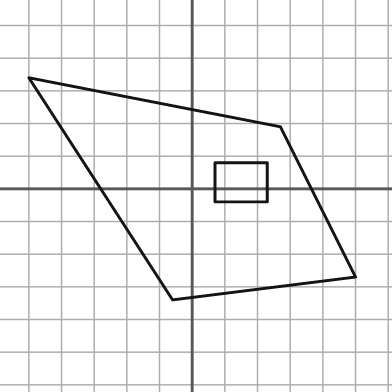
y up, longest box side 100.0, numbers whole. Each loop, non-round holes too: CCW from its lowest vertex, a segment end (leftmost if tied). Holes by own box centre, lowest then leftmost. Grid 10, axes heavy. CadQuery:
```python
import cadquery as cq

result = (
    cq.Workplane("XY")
    .moveTo(-6.0, -34.0)
    .lineTo(50.0, -27.0)
    .lineTo(27.0, 19.0)
    .lineTo(-50.0, 34.0)
    .close()
    .moveTo(7.0, -4.0)
    .lineTo(23.0, -4.0)
    .lineTo(23.0, 8.0)
    .lineTo(7.0, 8.0)
    .close()
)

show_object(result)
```